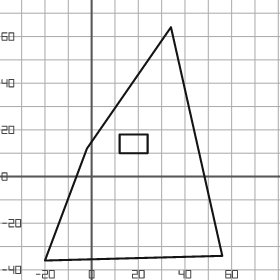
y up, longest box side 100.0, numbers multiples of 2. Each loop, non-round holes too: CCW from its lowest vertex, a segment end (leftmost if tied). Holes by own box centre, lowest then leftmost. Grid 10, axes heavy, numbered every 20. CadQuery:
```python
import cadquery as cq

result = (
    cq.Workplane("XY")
    .moveTo(-20.0, -36.0)
    .lineTo(56.0, -34.0)
    .lineTo(34.0, 64.0)
    .lineTo(-2.0, 12.0)
    .close()
    .moveTo(12.0, 10.0)
    .lineTo(24.0, 10.0)
    .lineTo(24.0, 18.0)
    .lineTo(12.0, 18.0)
    .close()
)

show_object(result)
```